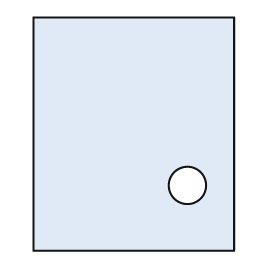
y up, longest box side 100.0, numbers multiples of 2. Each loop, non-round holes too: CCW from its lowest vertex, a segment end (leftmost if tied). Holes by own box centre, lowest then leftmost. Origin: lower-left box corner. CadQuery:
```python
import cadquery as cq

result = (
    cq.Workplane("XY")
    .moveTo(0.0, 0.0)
    .lineTo(86.0, 0.0)
    .lineTo(86.0, 100.0)
    .lineTo(0.0, 100.0)
    .close()
    .moveTo(66.0, 28.0)
    .circle(8.0)
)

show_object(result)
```